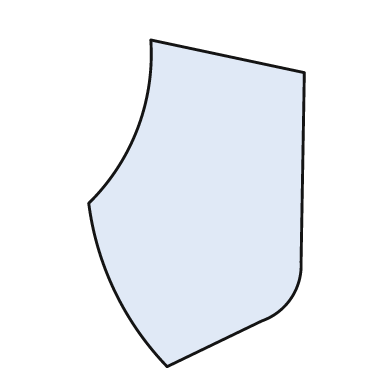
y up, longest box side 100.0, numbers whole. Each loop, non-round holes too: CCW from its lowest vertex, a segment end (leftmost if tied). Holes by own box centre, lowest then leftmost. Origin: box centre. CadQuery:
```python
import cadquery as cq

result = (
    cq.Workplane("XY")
    .moveTo(-9.0, -50.0)
    .lineTo(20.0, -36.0)
    .threePointArc((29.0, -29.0), (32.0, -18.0))
    .lineTo(33.0, 40.0)
    .lineTo(-14.0, 50.0)
    .threePointArc((-18.0, 23.0), (-33.0, 0.0))
    .threePointArc((-25.0, -27.0), (-9.0, -50.0))
    .close()
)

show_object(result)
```